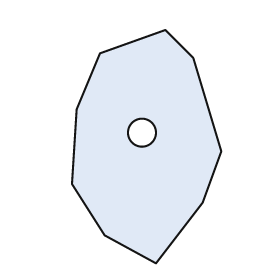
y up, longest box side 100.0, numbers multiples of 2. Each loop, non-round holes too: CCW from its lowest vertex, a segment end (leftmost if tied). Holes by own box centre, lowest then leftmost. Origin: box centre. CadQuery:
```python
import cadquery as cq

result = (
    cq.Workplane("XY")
    .moveTo(4.0, -50.0)
    .lineTo(24.0, -24.0)
    .lineTo(32.0, -2.0)
    .lineTo(20.0, 38.0)
    .lineTo(8.0, 50.0)
    .lineTo(-20.0, 40.0)
    .lineTo(-30.0, 16.0)
    .lineTo(-32.0, -16.0)
    .lineTo(-18.0, -38.0)
    .close()
    .moveTo(-2.0, 6.0)
    .circle(6.0)
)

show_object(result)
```